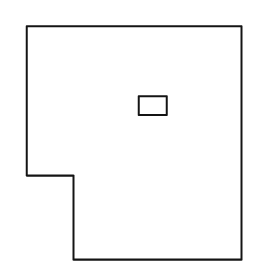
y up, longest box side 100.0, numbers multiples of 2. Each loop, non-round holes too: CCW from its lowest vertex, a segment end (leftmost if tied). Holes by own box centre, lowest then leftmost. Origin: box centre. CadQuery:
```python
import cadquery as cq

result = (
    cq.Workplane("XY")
    .moveTo(-26.0, -50.0)
    .lineTo(46.0, -50.0)
    .lineTo(46.0, 50.0)
    .lineTo(-46.0, 50.0)
    .lineTo(-46.0, -14.0)
    .lineTo(-26.0, -14.0)
    .close()
    .moveTo(2.0, 12.0)
    .lineTo(14.0, 12.0)
    .lineTo(14.0, 20.0)
    .lineTo(2.0, 20.0)
    .close()
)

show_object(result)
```